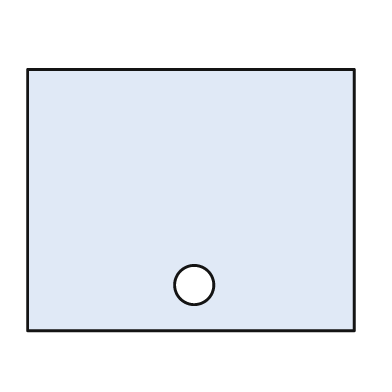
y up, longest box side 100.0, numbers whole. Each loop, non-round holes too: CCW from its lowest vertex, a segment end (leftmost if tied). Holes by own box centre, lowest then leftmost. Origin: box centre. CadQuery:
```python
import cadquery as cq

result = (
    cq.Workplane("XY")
    .moveTo(-50.0, -40.0)
    .lineTo(50.0, -40.0)
    .lineTo(50.0, 40.0)
    .lineTo(-50.0, 40.0)
    .close()
    .moveTo(1.0, -26.0)
    .circle(6.0)
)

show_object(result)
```